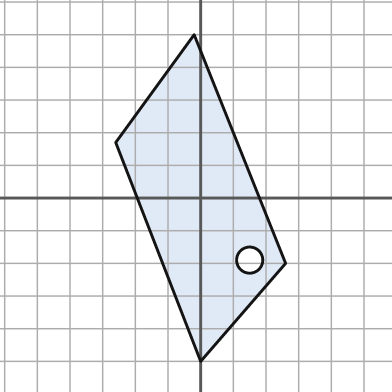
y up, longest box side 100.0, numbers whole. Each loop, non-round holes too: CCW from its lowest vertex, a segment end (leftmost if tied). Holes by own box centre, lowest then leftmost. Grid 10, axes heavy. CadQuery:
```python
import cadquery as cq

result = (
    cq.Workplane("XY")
    .moveTo(0.0, -50.0)
    .lineTo(26.0, -20.0)
    .lineTo(-2.0, 50.0)
    .lineTo(-26.0, 17.0)
    .close()
    .moveTo(15.0, -19.0)
    .circle(4.0)
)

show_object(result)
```